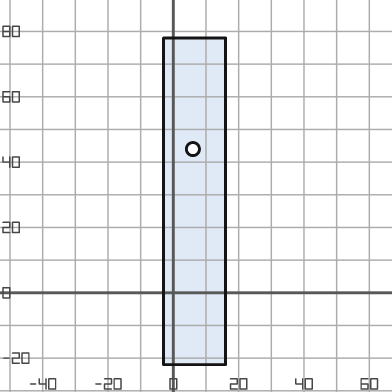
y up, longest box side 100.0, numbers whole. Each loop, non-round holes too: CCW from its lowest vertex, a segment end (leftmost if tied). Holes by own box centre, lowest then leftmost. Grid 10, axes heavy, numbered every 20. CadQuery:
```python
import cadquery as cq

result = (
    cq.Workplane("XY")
    .moveTo(-3.0, -22.0)
    .lineTo(16.0, -22.0)
    .lineTo(16.0, 78.0)
    .lineTo(-3.0, 78.0)
    .close()
    .moveTo(6.0, 44.0)
    .circle(2.0)
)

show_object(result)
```